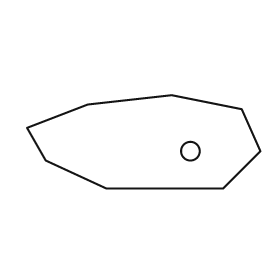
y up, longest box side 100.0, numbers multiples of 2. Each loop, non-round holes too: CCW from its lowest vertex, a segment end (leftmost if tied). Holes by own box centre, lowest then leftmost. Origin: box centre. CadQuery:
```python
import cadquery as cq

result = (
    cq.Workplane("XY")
    .moveTo(-16.0, -20.0)
    .lineTo(34.0, -20.0)
    .lineTo(50.0, -4.0)
    .lineTo(42.0, 14.0)
    .lineTo(12.0, 20.0)
    .lineTo(-24.0, 16.0)
    .lineTo(-50.0, 6.0)
    .lineTo(-42.0, -8.0)
    .close()
    .moveTo(20.0, -4.0)
    .circle(4.0)
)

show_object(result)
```